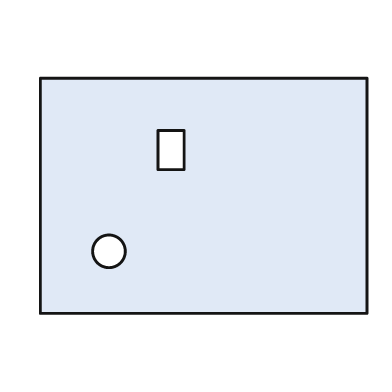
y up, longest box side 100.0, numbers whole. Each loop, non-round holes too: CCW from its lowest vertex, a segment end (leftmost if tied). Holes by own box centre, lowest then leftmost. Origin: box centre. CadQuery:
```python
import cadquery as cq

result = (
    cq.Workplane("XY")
    .moveTo(-50.0, -36.0)
    .lineTo(50.0, -36.0)
    .lineTo(50.0, 36.0)
    .lineTo(-50.0, 36.0)
    .close()
    .moveTo(-29.0, -17.0)
    .circle(5.0)
    .moveTo(-14.0, 8.0)
    .lineTo(-6.0, 8.0)
    .lineTo(-6.0, 20.0)
    .lineTo(-14.0, 20.0)
    .close()
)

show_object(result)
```